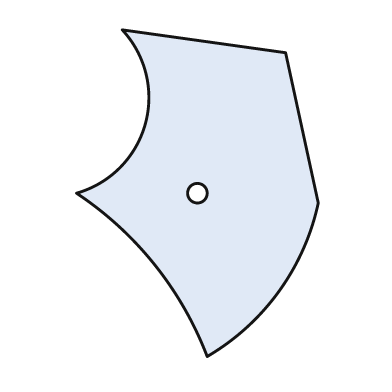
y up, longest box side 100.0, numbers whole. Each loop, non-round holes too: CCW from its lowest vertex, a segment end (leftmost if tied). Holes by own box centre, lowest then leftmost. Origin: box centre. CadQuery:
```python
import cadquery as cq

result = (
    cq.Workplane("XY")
    .moveTo(3.0, -50.0)
    .threePointArc((25.0, -30.0), (37.0, -3.0))
    .lineTo(27.0, 43.0)
    .lineTo(-23.0, 50.0)
    .threePointArc((-16.0, 21.0), (-37.0, 0.0))
    .threePointArc((-13.0, -22.0), (3.0, -50.0))
    .close()
    .moveTo(0.0, 0.0)
    .circle(3.0)
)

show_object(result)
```